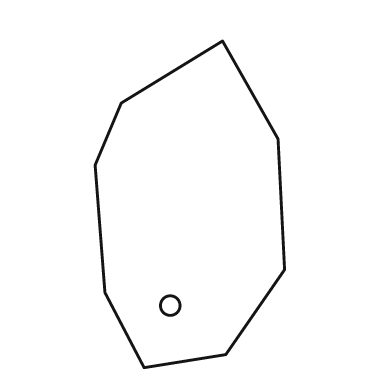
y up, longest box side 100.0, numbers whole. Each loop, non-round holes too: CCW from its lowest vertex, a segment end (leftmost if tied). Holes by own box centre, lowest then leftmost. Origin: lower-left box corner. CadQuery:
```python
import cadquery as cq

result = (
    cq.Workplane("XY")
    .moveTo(15.0, 0.0)
    .lineTo(40.0, 4.0)
    .lineTo(58.0, 30.0)
    .lineTo(56.0, 70.0)
    .lineTo(39.0, 100.0)
    .lineTo(8.0, 81.0)
    .lineTo(0.0, 62.0)
    .lineTo(3.0, 23.0)
    .close()
    .moveTo(23.0, 19.0)
    .circle(3.0)
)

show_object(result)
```